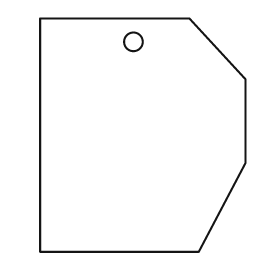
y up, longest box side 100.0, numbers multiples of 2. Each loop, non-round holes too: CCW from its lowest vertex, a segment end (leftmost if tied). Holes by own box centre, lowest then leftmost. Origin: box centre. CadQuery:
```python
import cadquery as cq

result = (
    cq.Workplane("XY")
    .moveTo(-44.0, -50.0)
    .lineTo(24.0, -50.0)
    .lineTo(44.0, -12.0)
    .lineTo(44.0, 24.0)
    .lineTo(20.0, 50.0)
    .lineTo(-44.0, 50.0)
    .close()
    .moveTo(-4.0, 40.0)
    .circle(4.0)
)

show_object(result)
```